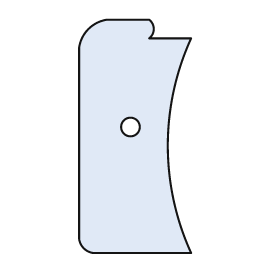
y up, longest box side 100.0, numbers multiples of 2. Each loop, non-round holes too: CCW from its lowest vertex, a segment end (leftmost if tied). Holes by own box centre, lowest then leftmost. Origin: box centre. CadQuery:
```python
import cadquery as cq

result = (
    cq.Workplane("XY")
    .moveTo(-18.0, -50.0)
    .lineTo(24.0, -50.0)
    .threePointArc((14.0, -4.0), (24.0, 42.0))
    .lineTo(6.0, 42.0)
    .threePointArc((8.0, 46.0), (6.0, 50.0))
    .lineTo(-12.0, 50.0)
    .threePointArc((-20.0, 46.0), (-24.0, 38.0))
    .lineTo(-24.0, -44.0)
    .threePointArc((-22.0, -48.0), (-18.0, -50.0))
    .close()
    .moveTo(-2.0, 4.0)
    .circle(4.0)
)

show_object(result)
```